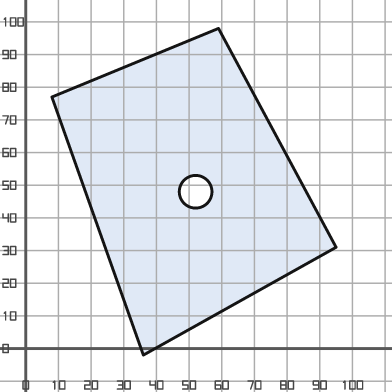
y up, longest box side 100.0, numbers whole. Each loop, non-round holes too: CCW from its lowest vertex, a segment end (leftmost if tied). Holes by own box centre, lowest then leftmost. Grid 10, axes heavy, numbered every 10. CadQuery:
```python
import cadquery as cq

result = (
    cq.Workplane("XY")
    .moveTo(36.0, -2.0)
    .lineTo(95.0, 31.0)
    .lineTo(59.0, 98.0)
    .lineTo(8.0, 77.0)
    .close()
    .moveTo(52.0, 48.0)
    .circle(5.0)
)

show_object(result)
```